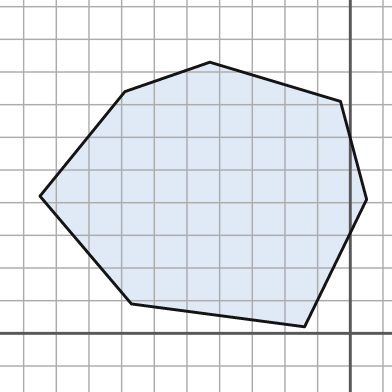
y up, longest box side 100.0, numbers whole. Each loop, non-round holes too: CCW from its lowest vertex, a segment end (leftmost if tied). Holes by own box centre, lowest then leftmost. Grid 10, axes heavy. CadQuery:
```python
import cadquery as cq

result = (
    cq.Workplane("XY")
    .moveTo(-14.0, 2.0)
    .lineTo(5.0, 41.0)
    .lineTo(-3.0, 71.0)
    .lineTo(-43.0, 83.0)
    .lineTo(-69.0, 74.0)
    .lineTo(-95.0, 42.0)
    .lineTo(-67.0, 9.0)
    .close()
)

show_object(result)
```